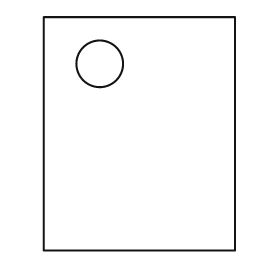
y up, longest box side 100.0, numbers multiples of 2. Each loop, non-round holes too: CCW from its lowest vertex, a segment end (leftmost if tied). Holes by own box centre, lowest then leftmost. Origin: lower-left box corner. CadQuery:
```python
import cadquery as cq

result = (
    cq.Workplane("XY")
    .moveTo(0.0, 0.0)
    .lineTo(82.0, 0.0)
    .lineTo(82.0, 100.0)
    .lineTo(0.0, 100.0)
    .close()
    .moveTo(24.0, 80.0)
    .circle(10.0)
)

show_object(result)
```